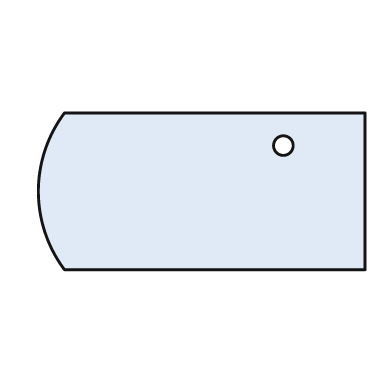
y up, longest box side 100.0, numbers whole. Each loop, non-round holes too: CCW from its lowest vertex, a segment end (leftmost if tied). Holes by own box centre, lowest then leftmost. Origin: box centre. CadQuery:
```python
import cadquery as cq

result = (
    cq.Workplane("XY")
    .moveTo(-42.0, -24.0)
    .lineTo(50.0, -24.0)
    .lineTo(50.0, 24.0)
    .lineTo(-42.0, 24.0)
    .threePointArc((-50.0, 0.0), (-42.0, -24.0))
    .close()
    .moveTo(25.0, 14.0)
    .circle(3.0)
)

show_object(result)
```